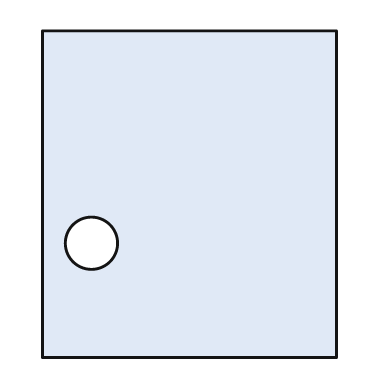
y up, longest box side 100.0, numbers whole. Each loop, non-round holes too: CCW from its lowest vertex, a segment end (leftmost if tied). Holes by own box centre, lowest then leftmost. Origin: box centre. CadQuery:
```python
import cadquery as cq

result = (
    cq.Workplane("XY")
    .moveTo(-45.0, -50.0)
    .lineTo(45.0, -50.0)
    .lineTo(45.0, 50.0)
    .lineTo(-45.0, 50.0)
    .close()
    .moveTo(-30.0, -15.0)
    .circle(8.0)
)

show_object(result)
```